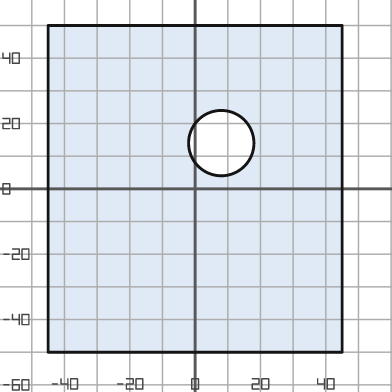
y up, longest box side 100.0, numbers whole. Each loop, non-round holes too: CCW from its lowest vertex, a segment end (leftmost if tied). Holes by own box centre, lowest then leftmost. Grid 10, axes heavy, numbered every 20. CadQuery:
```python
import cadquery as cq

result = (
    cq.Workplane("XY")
    .moveTo(-45.0, -50.0)
    .lineTo(45.0, -50.0)
    .lineTo(45.0, 50.0)
    .lineTo(-45.0, 50.0)
    .close()
    .moveTo(8.0, 14.0)
    .circle(10.0)
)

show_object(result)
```